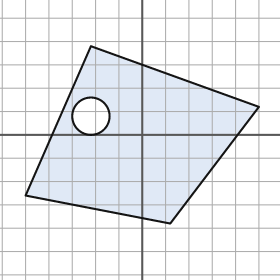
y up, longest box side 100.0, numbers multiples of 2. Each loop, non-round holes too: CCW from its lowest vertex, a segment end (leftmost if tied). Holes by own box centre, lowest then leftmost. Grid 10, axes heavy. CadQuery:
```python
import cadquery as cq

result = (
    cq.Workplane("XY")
    .moveTo(12.0, -38.0)
    .lineTo(50.0, 12.0)
    .lineTo(-22.0, 38.0)
    .lineTo(-50.0, -26.0)
    .close()
    .moveTo(-22.0, 8.0)
    .circle(8.0)
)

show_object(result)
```